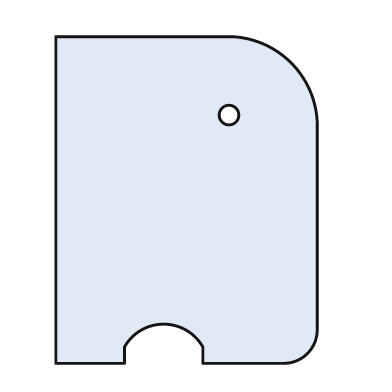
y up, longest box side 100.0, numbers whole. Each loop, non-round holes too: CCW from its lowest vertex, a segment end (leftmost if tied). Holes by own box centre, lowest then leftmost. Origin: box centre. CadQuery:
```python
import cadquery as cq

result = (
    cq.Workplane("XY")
    .moveTo(-40.0, -50.0)
    .lineTo(-19.0, -50.0)
    .lineTo(-19.0, -45.0)
    .threePointArc((-7.0, -38.0), (5.0, -45.0))
    .lineTo(5.0, -50.0)
    .lineTo(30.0, -50.0)
    .threePointArc((37.0, -47.0), (40.0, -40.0))
    .lineTo(40.0, 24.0)
    .threePointArc((32.0, 42.0), (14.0, 50.0))
    .lineTo(-40.0, 50.0)
    .close()
    .moveTo(13.0, 26.0)
    .circle(3.0)
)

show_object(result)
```